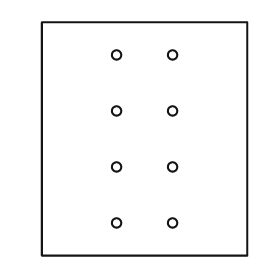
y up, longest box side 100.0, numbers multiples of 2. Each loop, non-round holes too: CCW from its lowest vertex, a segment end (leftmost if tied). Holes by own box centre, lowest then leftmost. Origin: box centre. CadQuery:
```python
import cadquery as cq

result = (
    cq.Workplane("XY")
    .moveTo(-44.0, -50.0)
    .lineTo(44.0, -50.0)
    .lineTo(44.0, 50.0)
    .lineTo(-44.0, 50.0)
    .close()
    .moveTo(-12.0, -36.0)
    .circle(2.0)
    .moveTo(12.0, -36.0)
    .circle(2.0)
    .moveTo(-12.0, -12.0)
    .circle(2.0)
    .moveTo(12.0, -12.0)
    .circle(2.0)
    .moveTo(-12.0, 12.0)
    .circle(2.0)
    .moveTo(12.0, 12.0)
    .circle(2.0)
    .moveTo(-12.0, 36.0)
    .circle(2.0)
    .moveTo(12.0, 36.0)
    .circle(2.0)
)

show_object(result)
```